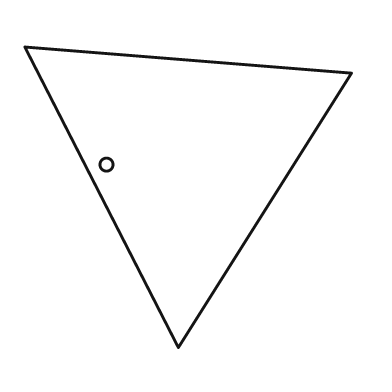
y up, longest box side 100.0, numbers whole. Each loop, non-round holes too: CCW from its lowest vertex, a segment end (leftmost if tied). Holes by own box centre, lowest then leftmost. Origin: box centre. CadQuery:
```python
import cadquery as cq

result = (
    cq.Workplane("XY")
    .moveTo(-3.0, -46.0)
    .lineTo(50.0, 38.0)
    .lineTo(-50.0, 46.0)
    .close()
    .moveTo(-25.0, 10.0)
    .circle(2.0)
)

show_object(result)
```